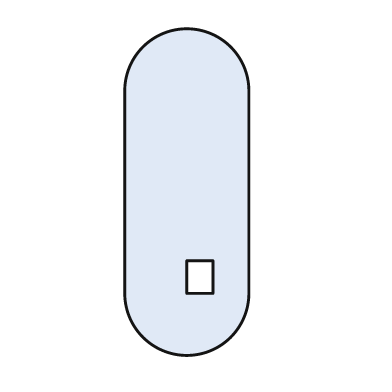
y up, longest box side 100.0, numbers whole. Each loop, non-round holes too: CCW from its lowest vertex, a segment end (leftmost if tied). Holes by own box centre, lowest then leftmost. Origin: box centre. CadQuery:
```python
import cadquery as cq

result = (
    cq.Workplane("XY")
    .moveTo(-19.0, -31.0)
    .threePointArc((0.0, -50.0), (19.0, -31.0))
    .lineTo(19.0, 31.0)
    .threePointArc((0.0, 50.0), (-19.0, 31.0))
    .close()
    .moveTo(0.0, -31.0)
    .lineTo(8.0, -31.0)
    .lineTo(8.0, -21.0)
    .lineTo(0.0, -21.0)
    .close()
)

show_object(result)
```